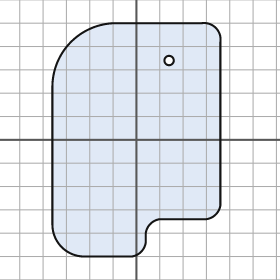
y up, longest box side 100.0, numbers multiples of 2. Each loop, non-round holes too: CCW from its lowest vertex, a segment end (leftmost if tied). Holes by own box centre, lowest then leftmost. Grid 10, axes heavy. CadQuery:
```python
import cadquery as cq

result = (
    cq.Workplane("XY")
    .moveTo(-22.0, -50.0)
    .lineTo(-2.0, -50.0)
    .threePointArc((2.0, -48.0), (4.0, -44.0))
    .lineTo(4.0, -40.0)
    .threePointArc((6.0, -36.0), (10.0, -34.0))
    .lineTo(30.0, -34.0)
    .threePointArc((34.0, -32.0), (36.0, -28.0))
    .lineTo(36.0, 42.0)
    .threePointArc((34.0, 48.0), (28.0, 50.0))
    .lineTo(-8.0, 50.0)
    .threePointArc((-28.0, 42.0), (-36.0, 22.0))
    .lineTo(-36.0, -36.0)
    .threePointArc((-32.0, -46.0), (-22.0, -50.0))
    .close()
    .moveTo(14.0, 34.0)
    .circle(2.0)
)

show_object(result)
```